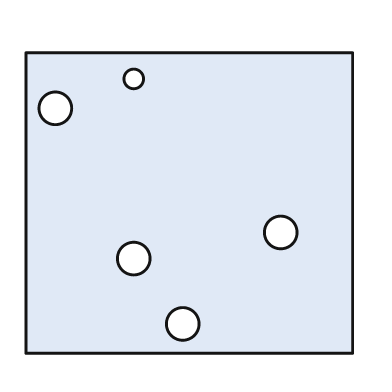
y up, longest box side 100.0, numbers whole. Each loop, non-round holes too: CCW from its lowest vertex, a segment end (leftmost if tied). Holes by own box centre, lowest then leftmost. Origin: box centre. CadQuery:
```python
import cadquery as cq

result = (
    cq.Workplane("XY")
    .moveTo(-50.0, -46.0)
    .lineTo(50.0, -46.0)
    .lineTo(50.0, 46.0)
    .lineTo(-50.0, 46.0)
    .close()
    .moveTo(-2.0, -37.0)
    .circle(5.0)
    .moveTo(-17.0, -17.0)
    .circle(5.0)
    .moveTo(28.0, -9.0)
    .circle(5.0)
    .moveTo(-41.0, 29.0)
    .circle(5.0)
    .moveTo(-17.0, 38.0)
    .circle(3.0)
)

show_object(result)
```